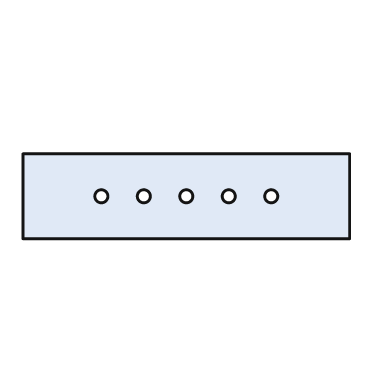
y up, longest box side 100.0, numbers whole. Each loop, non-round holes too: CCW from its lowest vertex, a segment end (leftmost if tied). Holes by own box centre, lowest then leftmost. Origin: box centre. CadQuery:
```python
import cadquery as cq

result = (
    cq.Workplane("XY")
    .moveTo(-50.0, -13.0)
    .lineTo(50.0, -13.0)
    .lineTo(50.0, 13.0)
    .lineTo(-50.0, 13.0)
    .close()
    .moveTo(-26.0, 0.0)
    .circle(2.0)
    .moveTo(-13.0, 0.0)
    .circle(2.0)
    .moveTo(0.0, 0.0)
    .circle(2.0)
    .moveTo(13.0, 0.0)
    .circle(2.0)
    .moveTo(26.0, 0.0)
    .circle(2.0)
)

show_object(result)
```